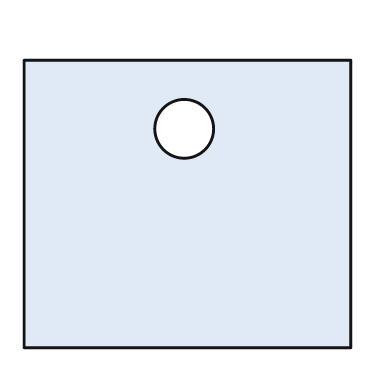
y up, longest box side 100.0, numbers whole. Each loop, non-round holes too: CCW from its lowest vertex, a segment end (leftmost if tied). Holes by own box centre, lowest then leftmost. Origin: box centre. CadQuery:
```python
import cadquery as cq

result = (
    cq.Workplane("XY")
    .moveTo(-50.0, -44.0)
    .lineTo(50.0, -44.0)
    .lineTo(50.0, 44.0)
    .lineTo(-50.0, 44.0)
    .close()
    .moveTo(-1.0, 23.0)
    .circle(9.0)
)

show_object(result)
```